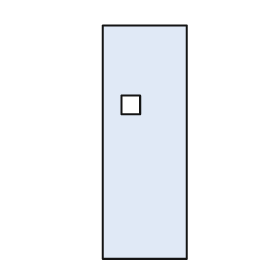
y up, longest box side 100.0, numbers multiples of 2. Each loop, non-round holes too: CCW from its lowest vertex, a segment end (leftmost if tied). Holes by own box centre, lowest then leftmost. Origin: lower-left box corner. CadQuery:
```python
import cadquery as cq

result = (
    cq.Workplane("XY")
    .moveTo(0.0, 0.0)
    .lineTo(36.0, 0.0)
    .lineTo(36.0, 100.0)
    .lineTo(0.0, 100.0)
    .close()
    .moveTo(8.0, 62.0)
    .lineTo(16.0, 62.0)
    .lineTo(16.0, 70.0)
    .lineTo(8.0, 70.0)
    .close()
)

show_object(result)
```